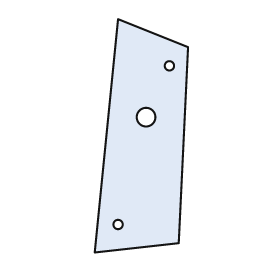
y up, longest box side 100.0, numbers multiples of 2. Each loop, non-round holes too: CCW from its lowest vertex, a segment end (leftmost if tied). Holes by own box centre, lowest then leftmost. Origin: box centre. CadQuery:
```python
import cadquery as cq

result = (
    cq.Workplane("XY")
    .moveTo(-20.0, -50.0)
    .lineTo(16.0, -46.0)
    .lineTo(20.0, 38.0)
    .lineTo(-10.0, 50.0)
    .close()
    .moveTo(-10.0, -38.0)
    .circle(2.0)
    .moveTo(2.0, 8.0)
    .circle(4.0)
    .moveTo(12.0, 30.0)
    .circle(2.0)
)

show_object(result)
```